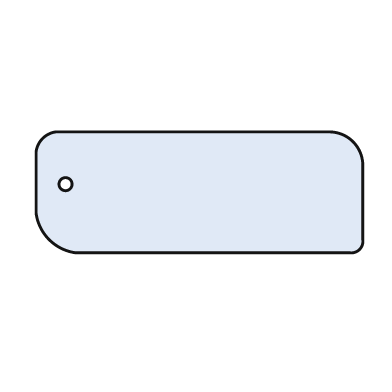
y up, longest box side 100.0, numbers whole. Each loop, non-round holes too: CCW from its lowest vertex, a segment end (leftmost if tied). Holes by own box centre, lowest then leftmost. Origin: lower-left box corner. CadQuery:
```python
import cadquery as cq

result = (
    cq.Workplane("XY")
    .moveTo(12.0, 0.0)
    .lineTo(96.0, 0.0)
    .threePointArc((99.0, 1.0), (100.0, 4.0))
    .lineTo(100.0, 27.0)
    .threePointArc((97.0, 34.0), (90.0, 37.0))
    .lineTo(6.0, 37.0)
    .threePointArc((2.0, 35.0), (0.0, 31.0))
    .lineTo(0.0, 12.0)
    .threePointArc((4.0, 4.0), (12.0, 0.0))
    .close()
    .moveTo(9.0, 21.0)
    .circle(2.0)
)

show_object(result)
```